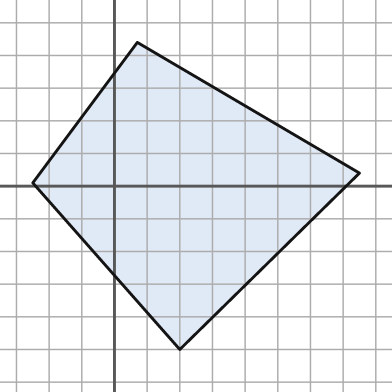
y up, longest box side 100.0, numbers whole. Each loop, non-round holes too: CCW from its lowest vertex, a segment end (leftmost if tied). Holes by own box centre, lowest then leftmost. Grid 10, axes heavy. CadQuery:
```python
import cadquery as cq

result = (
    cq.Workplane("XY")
    .moveTo(20.0, -50.0)
    .lineTo(75.0, 4.0)
    .lineTo(7.0, 44.0)
    .lineTo(-25.0, 1.0)
    .close()
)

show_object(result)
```